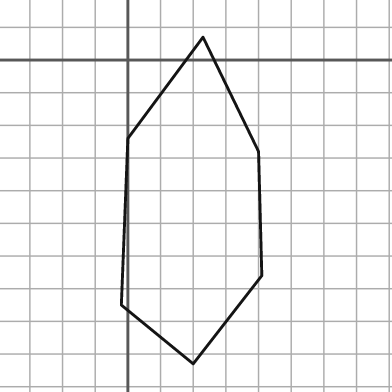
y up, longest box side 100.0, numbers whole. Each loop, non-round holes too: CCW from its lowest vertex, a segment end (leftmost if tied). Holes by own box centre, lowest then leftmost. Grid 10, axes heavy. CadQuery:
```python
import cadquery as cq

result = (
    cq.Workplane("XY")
    .moveTo(20.0, -93.0)
    .lineTo(41.0, -66.0)
    .lineTo(40.0, -28.0)
    .lineTo(23.0, 7.0)
    .lineTo(0.0, -24.0)
    .lineTo(-2.0, -75.0)
    .close()
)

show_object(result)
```